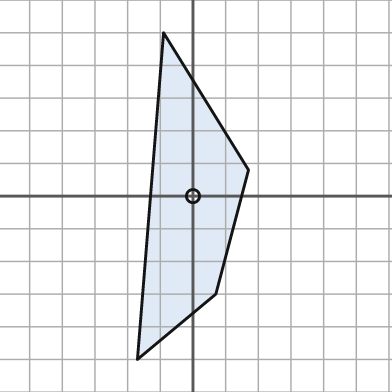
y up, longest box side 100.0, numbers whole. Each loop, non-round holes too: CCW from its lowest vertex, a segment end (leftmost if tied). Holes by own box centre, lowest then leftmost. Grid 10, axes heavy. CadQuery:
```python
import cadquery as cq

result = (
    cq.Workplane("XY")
    .moveTo(-17.0, -50.0)
    .lineTo(7.0, -30.0)
    .lineTo(17.0, 8.0)
    .lineTo(-9.0, 50.0)
    .close()
    .moveTo(0.0, 0.0)
    .circle(2.0)
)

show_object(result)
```